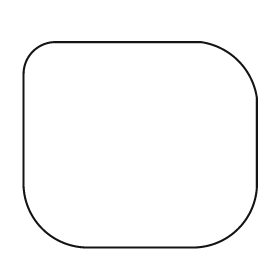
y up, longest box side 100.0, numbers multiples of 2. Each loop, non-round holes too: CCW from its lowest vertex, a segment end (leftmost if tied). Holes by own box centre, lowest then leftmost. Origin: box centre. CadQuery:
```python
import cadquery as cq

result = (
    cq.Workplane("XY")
    .moveTo(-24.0, -44.0)
    .lineTo(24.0, -44.0)
    .threePointArc((42.0, -36.0), (50.0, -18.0))
    .lineTo(50.0, 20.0)
    .threePointArc((42.0, 36.0), (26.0, 44.0))
    .lineTo(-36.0, 44.0)
    .threePointArc((-46.0, 40.0), (-50.0, 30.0))
    .lineTo(-50.0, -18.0)
    .threePointArc((-42.0, -36.0), (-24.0, -44.0))
    .close()
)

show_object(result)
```